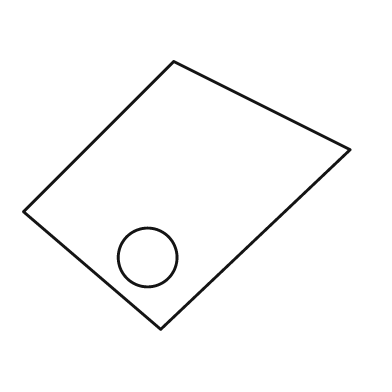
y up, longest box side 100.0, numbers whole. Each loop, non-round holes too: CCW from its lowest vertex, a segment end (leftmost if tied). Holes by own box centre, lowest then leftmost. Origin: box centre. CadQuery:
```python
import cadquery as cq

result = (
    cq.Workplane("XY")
    .moveTo(-8.0, -41.0)
    .lineTo(50.0, 14.0)
    .lineTo(-4.0, 41.0)
    .lineTo(-50.0, -5.0)
    .close()
    .moveTo(-12.0, -19.0)
    .circle(9.0)
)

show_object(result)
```